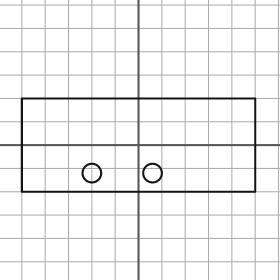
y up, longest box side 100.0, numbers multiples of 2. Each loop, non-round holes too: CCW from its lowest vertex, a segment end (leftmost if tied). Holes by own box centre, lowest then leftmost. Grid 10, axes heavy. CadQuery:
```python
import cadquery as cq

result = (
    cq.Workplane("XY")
    .moveTo(-50.0, -20.0)
    .lineTo(50.0, -20.0)
    .lineTo(50.0, 20.0)
    .lineTo(-50.0, 20.0)
    .close()
    .moveTo(-20.0, -12.0)
    .circle(4.0)
    .moveTo(6.0, -12.0)
    .circle(4.0)
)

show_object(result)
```